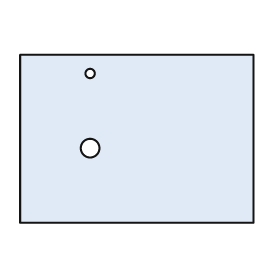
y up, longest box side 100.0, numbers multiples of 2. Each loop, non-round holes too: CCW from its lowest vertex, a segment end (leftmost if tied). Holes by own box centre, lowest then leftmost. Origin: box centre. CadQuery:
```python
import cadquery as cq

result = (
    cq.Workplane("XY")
    .moveTo(-50.0, -36.0)
    .lineTo(50.0, -36.0)
    .lineTo(50.0, 36.0)
    .lineTo(-50.0, 36.0)
    .close()
    .moveTo(-20.0, -4.0)
    .circle(4.0)
    .moveTo(-20.0, 28.0)
    .circle(2.0)
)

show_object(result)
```